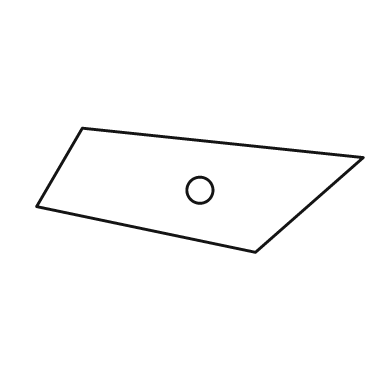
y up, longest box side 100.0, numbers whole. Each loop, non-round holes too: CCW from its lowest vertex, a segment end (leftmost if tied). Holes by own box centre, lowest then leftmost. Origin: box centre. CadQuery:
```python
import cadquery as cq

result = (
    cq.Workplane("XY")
    .moveTo(17.0, -19.0)
    .lineTo(50.0, 10.0)
    .lineTo(-36.0, 19.0)
    .lineTo(-50.0, -5.0)
    .close()
    .moveTo(0.0, 0.0)
    .circle(4.0)
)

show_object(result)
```